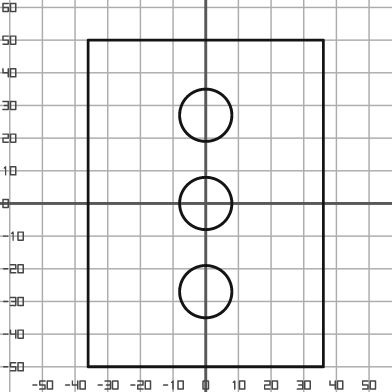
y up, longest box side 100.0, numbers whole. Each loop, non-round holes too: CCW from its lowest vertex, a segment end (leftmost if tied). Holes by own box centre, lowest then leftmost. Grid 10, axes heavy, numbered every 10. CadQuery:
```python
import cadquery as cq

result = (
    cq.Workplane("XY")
    .moveTo(-36.0, -50.0)
    .lineTo(36.0, -50.0)
    .lineTo(36.0, 50.0)
    .lineTo(-36.0, 50.0)
    .close()
    .moveTo(0.0, -27.0)
    .circle(8.0)
    .moveTo(0.0, 0.0)
    .circle(8.0)
    .moveTo(0.0, 27.0)
    .circle(8.0)
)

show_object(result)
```